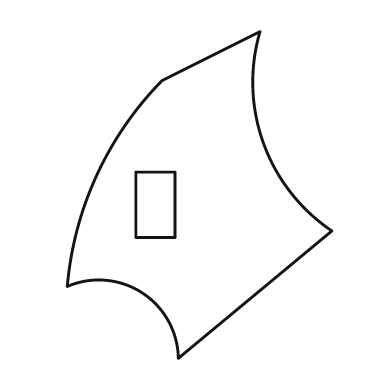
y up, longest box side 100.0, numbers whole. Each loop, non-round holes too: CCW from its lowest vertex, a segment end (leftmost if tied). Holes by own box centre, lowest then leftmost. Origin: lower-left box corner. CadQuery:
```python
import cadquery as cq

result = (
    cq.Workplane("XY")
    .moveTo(34.0, 0.0)
    .lineTo(81.0, 39.0)
    .threePointArc((60.0, 66.0), (59.0, 100.0))
    .lineTo(29.0, 85.0)
    .threePointArc((9.0, 56.0), (0.0, 22.0))
    .threePointArc((23.0, 20.0), (34.0, 0.0))
    .close()
    .moveTo(21.0, 37.0)
    .lineTo(33.0, 37.0)
    .lineTo(33.0, 57.0)
    .lineTo(21.0, 57.0)
    .close()
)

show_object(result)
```